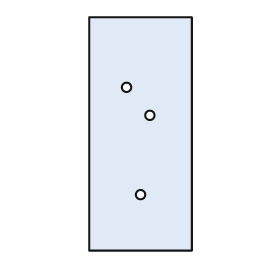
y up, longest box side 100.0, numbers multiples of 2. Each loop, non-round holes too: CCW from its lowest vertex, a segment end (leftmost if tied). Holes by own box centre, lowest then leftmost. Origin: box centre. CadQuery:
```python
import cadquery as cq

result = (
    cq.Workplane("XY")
    .moveTo(-22.0, -50.0)
    .lineTo(22.0, -50.0)
    .lineTo(22.0, 50.0)
    .lineTo(-22.0, 50.0)
    .close()
    .moveTo(0.0, -26.0)
    .circle(2.0)
    .moveTo(4.0, 8.0)
    .circle(2.0)
    .moveTo(-6.0, 20.0)
    .circle(2.0)
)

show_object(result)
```